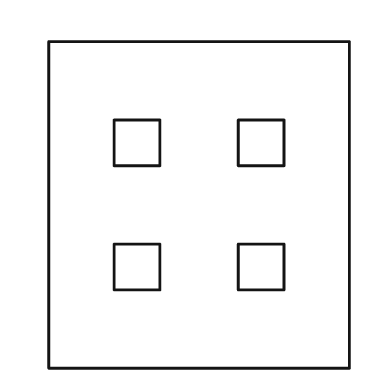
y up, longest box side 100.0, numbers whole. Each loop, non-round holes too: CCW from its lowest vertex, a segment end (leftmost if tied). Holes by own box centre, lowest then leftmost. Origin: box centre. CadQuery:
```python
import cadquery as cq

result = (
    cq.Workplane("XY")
    .moveTo(-46.0, -50.0)
    .lineTo(46.0, -50.0)
    .lineTo(46.0, 50.0)
    .lineTo(-46.0, 50.0)
    .close()
    .moveTo(-26.0, -26.0)
    .lineTo(-12.0, -26.0)
    .lineTo(-12.0, -12.0)
    .lineTo(-26.0, -12.0)
    .close()
    .moveTo(12.0, -26.0)
    .lineTo(26.0, -26.0)
    .lineTo(26.0, -12.0)
    .lineTo(12.0, -12.0)
    .close()
    .moveTo(-26.0, 12.0)
    .lineTo(-12.0, 12.0)
    .lineTo(-12.0, 26.0)
    .lineTo(-26.0, 26.0)
    .close()
    .moveTo(12.0, 12.0)
    .lineTo(26.0, 12.0)
    .lineTo(26.0, 26.0)
    .lineTo(12.0, 26.0)
    .close()
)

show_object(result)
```